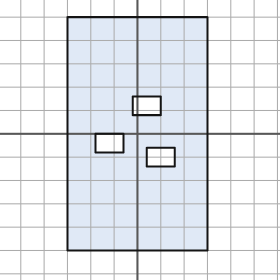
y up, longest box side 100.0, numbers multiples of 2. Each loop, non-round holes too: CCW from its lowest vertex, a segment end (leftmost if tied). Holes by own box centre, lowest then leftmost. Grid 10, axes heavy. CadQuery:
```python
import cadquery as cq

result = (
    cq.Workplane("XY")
    .moveTo(-30.0, -50.0)
    .lineTo(30.0, -50.0)
    .lineTo(30.0, 50.0)
    .lineTo(-30.0, 50.0)
    .close()
    .moveTo(4.0, -14.0)
    .lineTo(16.0, -14.0)
    .lineTo(16.0, -6.0)
    .lineTo(4.0, -6.0)
    .close()
    .moveTo(-18.0, -8.0)
    .lineTo(-6.0, -8.0)
    .lineTo(-6.0, 0.0)
    .lineTo(-18.0, 0.0)
    .close()
    .moveTo(-2.0, 8.0)
    .lineTo(10.0, 8.0)
    .lineTo(10.0, 16.0)
    .lineTo(-2.0, 16.0)
    .close()
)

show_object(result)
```